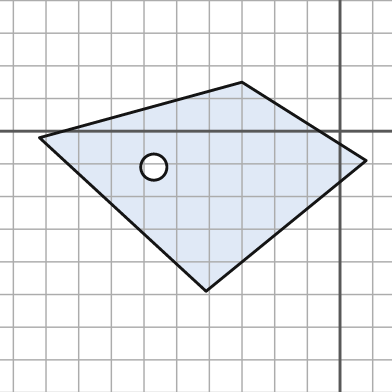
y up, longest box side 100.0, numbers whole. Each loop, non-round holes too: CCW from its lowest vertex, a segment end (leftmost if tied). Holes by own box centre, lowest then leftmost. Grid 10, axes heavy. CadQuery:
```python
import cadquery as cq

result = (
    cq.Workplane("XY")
    .moveTo(-41.0, -49.0)
    .lineTo(8.0, -9.0)
    .lineTo(-30.0, 15.0)
    .lineTo(-92.0, -2.0)
    .close()
    .moveTo(-57.0, -11.0)
    .circle(4.0)
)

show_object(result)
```